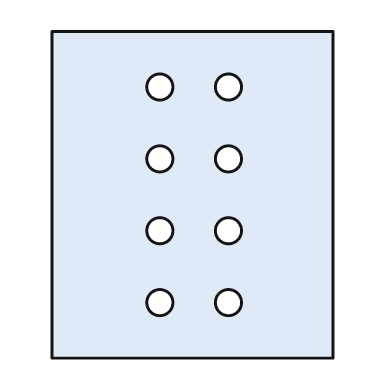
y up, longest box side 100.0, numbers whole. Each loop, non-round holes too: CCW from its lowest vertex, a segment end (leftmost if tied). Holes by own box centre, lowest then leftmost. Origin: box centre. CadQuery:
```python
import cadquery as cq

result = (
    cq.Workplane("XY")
    .moveTo(-43.0, -50.0)
    .lineTo(43.0, -50.0)
    .lineTo(43.0, 50.0)
    .lineTo(-43.0, 50.0)
    .close()
    .moveTo(-10.0, -33.0)
    .circle(4.0)
    .moveTo(11.0, -33.0)
    .circle(4.0)
    .moveTo(-10.0, -11.0)
    .circle(4.0)
    .moveTo(11.0, -11.0)
    .circle(4.0)
    .moveTo(-10.0, 11.0)
    .circle(4.0)
    .moveTo(11.0, 11.0)
    .circle(4.0)
    .moveTo(-10.0, 33.0)
    .circle(4.0)
    .moveTo(11.0, 33.0)
    .circle(4.0)
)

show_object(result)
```